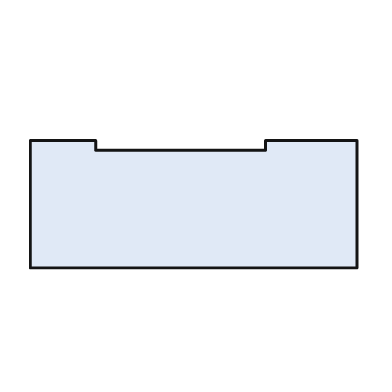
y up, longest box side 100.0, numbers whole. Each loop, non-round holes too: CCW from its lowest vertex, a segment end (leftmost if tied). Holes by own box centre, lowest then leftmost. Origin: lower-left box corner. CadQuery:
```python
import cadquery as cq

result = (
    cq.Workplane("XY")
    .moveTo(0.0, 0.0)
    .lineTo(100.0, 0.0)
    .lineTo(100.0, 39.0)
    .lineTo(72.0, 39.0)
    .lineTo(72.0, 36.0)
    .lineTo(20.0, 36.0)
    .lineTo(20.0, 39.0)
    .lineTo(0.0, 39.0)
    .close()
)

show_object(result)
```